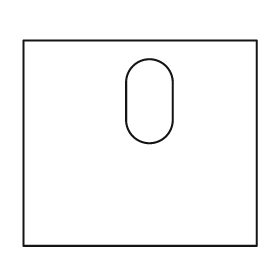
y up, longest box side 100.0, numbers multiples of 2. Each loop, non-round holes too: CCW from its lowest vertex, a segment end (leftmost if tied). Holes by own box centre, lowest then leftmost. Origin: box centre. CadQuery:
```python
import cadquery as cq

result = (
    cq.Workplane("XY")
    .moveTo(-50.0, -44.0)
    .lineTo(50.0, -44.0)
    .lineTo(50.0, 44.0)
    .lineTo(-50.0, 44.0)
    .close()
    .moveTo(-6.0, 10.0)
    .threePointArc((4.0, 0.0), (14.0, 10.0))
    .lineTo(14.0, 26.0)
    .threePointArc((4.0, 36.0), (-6.0, 26.0))
    .close()
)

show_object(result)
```